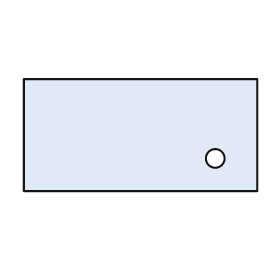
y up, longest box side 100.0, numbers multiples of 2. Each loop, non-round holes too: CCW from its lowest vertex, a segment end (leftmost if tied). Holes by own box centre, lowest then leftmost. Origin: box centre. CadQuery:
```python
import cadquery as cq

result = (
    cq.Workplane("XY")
    .moveTo(-50.0, -24.0)
    .lineTo(50.0, -24.0)
    .lineTo(50.0, 24.0)
    .lineTo(-50.0, 24.0)
    .close()
    .moveTo(32.0, -10.0)
    .circle(4.0)
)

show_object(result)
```